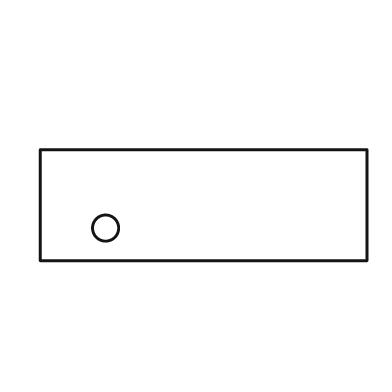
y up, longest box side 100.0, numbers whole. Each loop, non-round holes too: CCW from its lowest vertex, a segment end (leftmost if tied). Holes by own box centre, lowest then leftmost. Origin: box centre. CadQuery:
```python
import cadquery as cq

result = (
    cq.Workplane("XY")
    .moveTo(-50.0, -17.0)
    .lineTo(50.0, -17.0)
    .lineTo(50.0, 17.0)
    .lineTo(-50.0, 17.0)
    .close()
    .moveTo(-30.0, -7.0)
    .circle(4.0)
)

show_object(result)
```